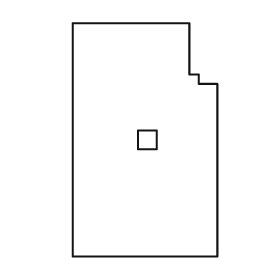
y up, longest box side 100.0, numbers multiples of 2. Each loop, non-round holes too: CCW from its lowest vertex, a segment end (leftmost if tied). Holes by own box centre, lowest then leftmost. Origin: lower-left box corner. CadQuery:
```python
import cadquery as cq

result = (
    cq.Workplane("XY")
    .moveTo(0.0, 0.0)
    .lineTo(62.0, 0.0)
    .lineTo(62.0, 74.0)
    .lineTo(54.0, 74.0)
    .lineTo(54.0, 78.0)
    .lineTo(50.0, 78.0)
    .lineTo(50.0, 100.0)
    .lineTo(0.0, 100.0)
    .close()
    .moveTo(28.0, 46.0)
    .lineTo(36.0, 46.0)
    .lineTo(36.0, 54.0)
    .lineTo(28.0, 54.0)
    .close()
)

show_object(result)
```